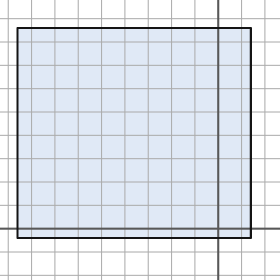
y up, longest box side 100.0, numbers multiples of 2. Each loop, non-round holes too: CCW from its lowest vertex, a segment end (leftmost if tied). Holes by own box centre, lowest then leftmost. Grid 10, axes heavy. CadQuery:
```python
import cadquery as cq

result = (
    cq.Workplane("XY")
    .moveTo(-86.0, -4.0)
    .lineTo(14.0, -4.0)
    .lineTo(14.0, 86.0)
    .lineTo(-86.0, 86.0)
    .close()
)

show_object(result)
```